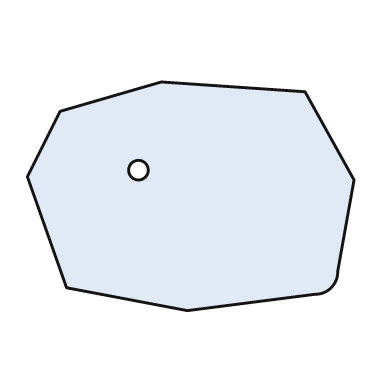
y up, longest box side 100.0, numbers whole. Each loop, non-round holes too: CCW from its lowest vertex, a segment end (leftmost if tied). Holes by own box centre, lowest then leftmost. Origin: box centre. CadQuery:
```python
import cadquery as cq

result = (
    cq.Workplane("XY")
    .moveTo(-1.0, -35.0)
    .lineTo(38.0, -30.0)
    .threePointArc((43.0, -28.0), (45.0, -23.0))
    .lineTo(50.0, 5.0)
    .lineTo(35.0, 32.0)
    .lineTo(-9.0, 35.0)
    .lineTo(-40.0, 26.0)
    .lineTo(-50.0, 6.0)
    .lineTo(-38.0, -28.0)
    .close()
    .moveTo(-16.0, 8.0)
    .circle(3.0)
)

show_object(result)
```